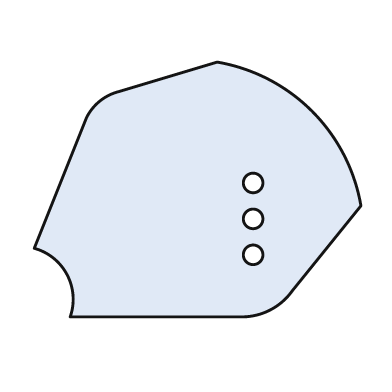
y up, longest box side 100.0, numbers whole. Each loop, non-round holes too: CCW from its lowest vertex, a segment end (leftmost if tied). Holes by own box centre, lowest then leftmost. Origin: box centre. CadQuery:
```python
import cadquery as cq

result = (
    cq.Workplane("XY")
    .moveTo(-39.0, -39.0)
    .lineTo(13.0, -39.0)
    .threePointArc((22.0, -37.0), (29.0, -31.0))
    .lineTo(50.0, -5.0)
    .threePointArc((35.0, 24.0), (6.0, 39.0))
    .lineTo(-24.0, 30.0)
    .threePointArc((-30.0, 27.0), (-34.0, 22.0))
    .lineTo(-50.0, -18.0)
    .threePointArc((-40.0, -26.0), (-39.0, -39.0))
    .close()
    .moveTo(17.0, -20.0)
    .circle(3.0)
    .moveTo(17.0, -9.0)
    .circle(3.0)
    .moveTo(17.0, 2.0)
    .circle(3.0)
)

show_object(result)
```